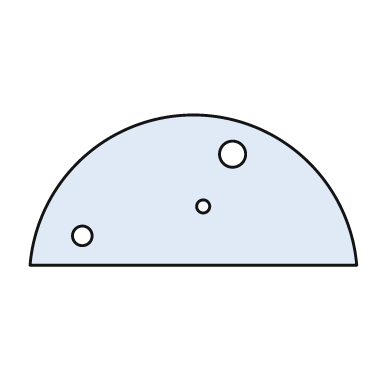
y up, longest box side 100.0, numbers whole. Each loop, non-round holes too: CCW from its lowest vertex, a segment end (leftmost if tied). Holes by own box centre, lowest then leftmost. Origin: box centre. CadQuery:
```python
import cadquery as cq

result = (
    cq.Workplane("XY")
    .moveTo(-50.0, -23.0)
    .lineTo(50.0, -23.0)
    .threePointArc((0.0, 23.0), (-50.0, -23.0))
    .close()
    .moveTo(-34.0, -14.0)
    .circle(3.0)
    .moveTo(3.0, -5.0)
    .circle(2.0)
    .moveTo(12.0, 11.0)
    .circle(4.0)
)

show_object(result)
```